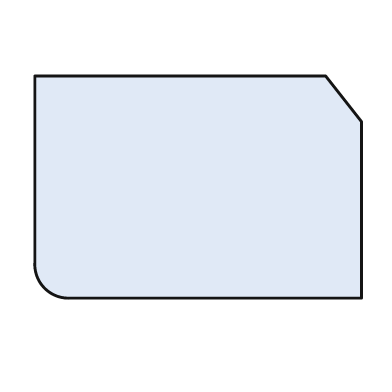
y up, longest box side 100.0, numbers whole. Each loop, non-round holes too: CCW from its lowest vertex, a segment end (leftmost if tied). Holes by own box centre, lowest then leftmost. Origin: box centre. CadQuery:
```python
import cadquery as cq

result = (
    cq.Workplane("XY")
    .moveTo(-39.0, -34.0)
    .lineTo(50.0, -34.0)
    .lineTo(50.0, 20.0)
    .lineTo(39.0, 34.0)
    .lineTo(-50.0, 34.0)
    .lineTo(-50.0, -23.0)
    .threePointArc((-47.0, -31.0), (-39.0, -34.0))
    .close()
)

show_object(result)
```